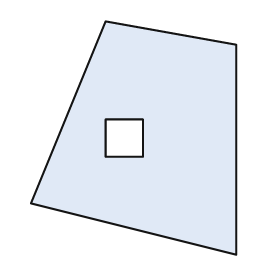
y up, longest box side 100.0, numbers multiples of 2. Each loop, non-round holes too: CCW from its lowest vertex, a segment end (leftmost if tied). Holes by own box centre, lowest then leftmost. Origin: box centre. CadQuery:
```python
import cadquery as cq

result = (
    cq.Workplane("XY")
    .moveTo(44.0, -50.0)
    .lineTo(44.0, 40.0)
    .lineTo(-12.0, 50.0)
    .lineTo(-44.0, -28.0)
    .close()
    .moveTo(-12.0, -8.0)
    .lineTo(4.0, -8.0)
    .lineTo(4.0, 8.0)
    .lineTo(-12.0, 8.0)
    .close()
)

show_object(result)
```